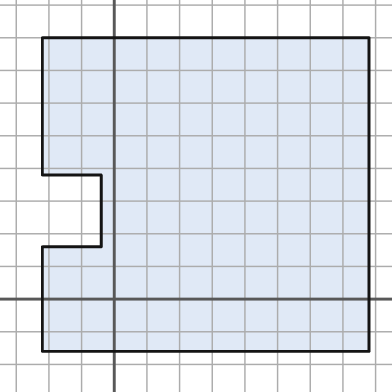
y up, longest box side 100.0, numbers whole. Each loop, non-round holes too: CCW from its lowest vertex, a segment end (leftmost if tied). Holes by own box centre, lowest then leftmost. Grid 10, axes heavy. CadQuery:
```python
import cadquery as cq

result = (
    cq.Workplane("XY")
    .moveTo(-22.0, -16.0)
    .lineTo(78.0, -16.0)
    .lineTo(78.0, 80.0)
    .lineTo(-22.0, 80.0)
    .lineTo(-22.0, 38.0)
    .lineTo(-4.0, 38.0)
    .lineTo(-4.0, 16.0)
    .lineTo(-22.0, 16.0)
    .close()
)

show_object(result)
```